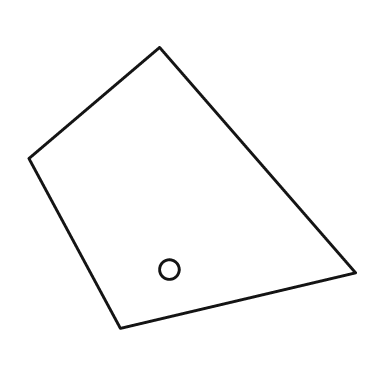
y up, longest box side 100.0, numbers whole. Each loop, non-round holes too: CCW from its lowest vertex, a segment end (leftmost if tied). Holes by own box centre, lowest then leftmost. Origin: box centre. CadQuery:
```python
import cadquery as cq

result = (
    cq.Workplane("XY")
    .moveTo(-22.0, -43.0)
    .lineTo(50.0, -26.0)
    .lineTo(-10.0, 43.0)
    .lineTo(-50.0, 9.0)
    .close()
    .moveTo(-7.0, -25.0)
    .circle(3.0)
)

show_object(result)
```